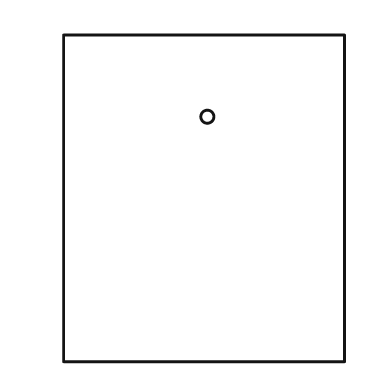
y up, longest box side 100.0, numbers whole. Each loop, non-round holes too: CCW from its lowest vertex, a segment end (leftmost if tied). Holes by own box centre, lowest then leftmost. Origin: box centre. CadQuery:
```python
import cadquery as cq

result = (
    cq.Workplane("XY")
    .moveTo(-43.0, -50.0)
    .lineTo(43.0, -50.0)
    .lineTo(43.0, 50.0)
    .lineTo(-43.0, 50.0)
    .close()
    .moveTo(1.0, 25.0)
    .circle(2.0)
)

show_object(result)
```